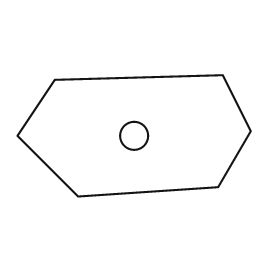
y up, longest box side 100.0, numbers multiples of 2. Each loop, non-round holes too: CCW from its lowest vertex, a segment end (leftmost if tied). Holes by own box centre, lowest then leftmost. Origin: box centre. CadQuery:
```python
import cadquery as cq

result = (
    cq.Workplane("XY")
    .moveTo(-24.0, -26.0)
    .lineTo(36.0, -22.0)
    .lineTo(50.0, 2.0)
    .lineTo(38.0, 26.0)
    .lineTo(-34.0, 24.0)
    .lineTo(-50.0, 0.0)
    .close()
    .moveTo(0.0, 0.0)
    .circle(6.0)
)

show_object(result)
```